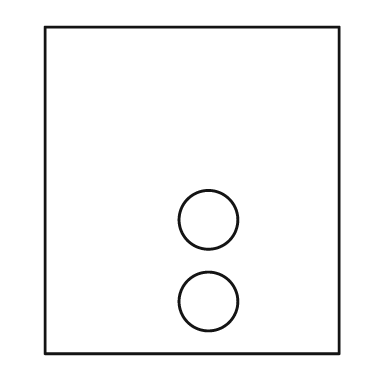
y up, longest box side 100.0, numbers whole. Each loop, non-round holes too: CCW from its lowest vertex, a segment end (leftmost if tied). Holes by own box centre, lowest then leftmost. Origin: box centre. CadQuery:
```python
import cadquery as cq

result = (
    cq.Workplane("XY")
    .moveTo(-45.0, -50.0)
    .lineTo(45.0, -50.0)
    .lineTo(45.0, 50.0)
    .lineTo(-45.0, 50.0)
    .close()
    .moveTo(5.0, -34.0)
    .circle(9.0)
    .moveTo(5.0, -9.0)
    .circle(9.0)
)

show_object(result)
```